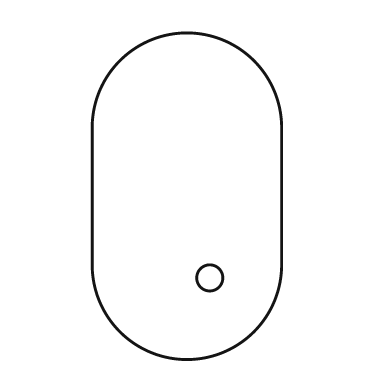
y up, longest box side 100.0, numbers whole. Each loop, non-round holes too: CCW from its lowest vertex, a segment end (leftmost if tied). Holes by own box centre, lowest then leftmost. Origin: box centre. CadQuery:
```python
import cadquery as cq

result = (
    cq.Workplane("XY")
    .moveTo(-29.0, -21.0)
    .threePointArc((0.0, -50.0), (29.0, -21.0))
    .lineTo(29.0, 21.0)
    .threePointArc((0.0, 50.0), (-29.0, 21.0))
    .close()
    .moveTo(7.0, -25.0)
    .circle(4.0)
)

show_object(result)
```